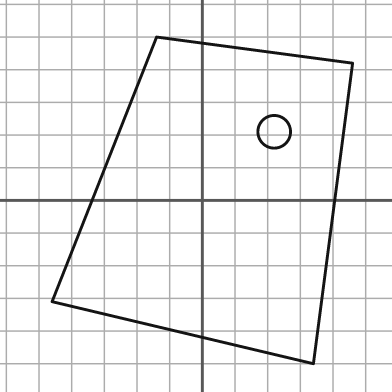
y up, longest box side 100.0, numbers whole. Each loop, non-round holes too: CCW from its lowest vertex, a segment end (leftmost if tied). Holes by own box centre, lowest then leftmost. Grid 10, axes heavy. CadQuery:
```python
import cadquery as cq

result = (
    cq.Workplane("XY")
    .moveTo(34.0, -50.0)
    .lineTo(46.0, 42.0)
    .lineTo(-14.0, 50.0)
    .lineTo(-46.0, -31.0)
    .close()
    .moveTo(22.0, 21.0)
    .circle(5.0)
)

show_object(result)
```